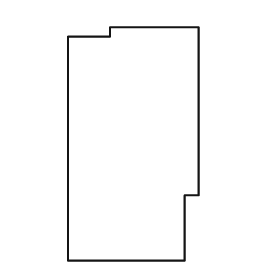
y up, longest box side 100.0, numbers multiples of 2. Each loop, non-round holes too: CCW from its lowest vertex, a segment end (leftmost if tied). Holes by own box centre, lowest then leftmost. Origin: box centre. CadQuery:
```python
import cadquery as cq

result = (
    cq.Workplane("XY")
    .moveTo(-28.0, -50.0)
    .lineTo(22.0, -50.0)
    .lineTo(22.0, -22.0)
    .lineTo(28.0, -22.0)
    .lineTo(28.0, 50.0)
    .lineTo(-10.0, 50.0)
    .lineTo(-10.0, 46.0)
    .lineTo(-28.0, 46.0)
    .close()
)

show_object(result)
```